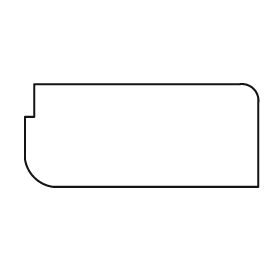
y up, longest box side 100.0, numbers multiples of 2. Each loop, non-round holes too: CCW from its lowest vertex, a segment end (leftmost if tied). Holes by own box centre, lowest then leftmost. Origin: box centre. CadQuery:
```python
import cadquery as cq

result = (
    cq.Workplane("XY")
    .moveTo(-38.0, -22.0)
    .lineTo(50.0, -22.0)
    .lineTo(50.0, 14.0)
    .threePointArc((48.0, 20.0), (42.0, 22.0))
    .lineTo(-46.0, 22.0)
    .lineTo(-46.0, 8.0)
    .lineTo(-50.0, 8.0)
    .lineTo(-50.0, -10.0)
    .threePointArc((-46.0, -18.0), (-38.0, -22.0))
    .close()
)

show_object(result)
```